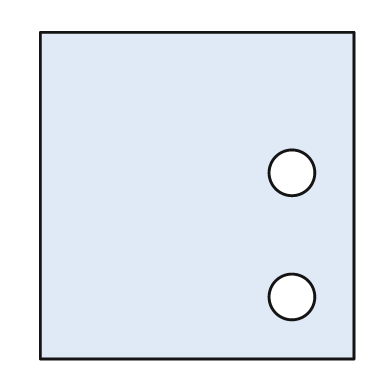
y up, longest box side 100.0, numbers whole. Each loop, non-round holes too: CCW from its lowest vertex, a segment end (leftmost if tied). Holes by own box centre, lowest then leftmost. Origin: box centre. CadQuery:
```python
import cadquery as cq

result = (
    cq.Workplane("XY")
    .moveTo(-48.0, -50.0)
    .lineTo(48.0, -50.0)
    .lineTo(48.0, 50.0)
    .lineTo(-48.0, 50.0)
    .close()
    .moveTo(29.0, -31.0)
    .circle(7.0)
    .moveTo(29.0, 7.0)
    .circle(7.0)
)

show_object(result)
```